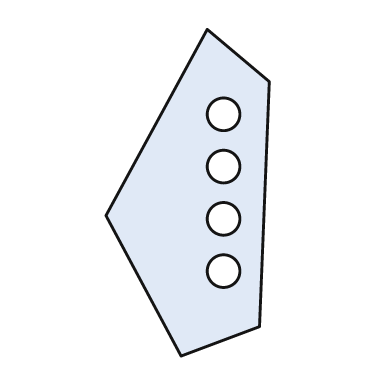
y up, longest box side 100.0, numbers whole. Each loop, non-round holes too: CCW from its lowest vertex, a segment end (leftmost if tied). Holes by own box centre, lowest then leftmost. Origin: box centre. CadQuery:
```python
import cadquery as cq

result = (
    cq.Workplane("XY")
    .moveTo(-2.0, -50.0)
    .lineTo(22.0, -41.0)
    .lineTo(25.0, 34.0)
    .lineTo(6.0, 50.0)
    .lineTo(-25.0, -7.0)
    .close()
    .moveTo(11.0, -24.0)
    .circle(5.0)
    .moveTo(11.0, -8.0)
    .circle(5.0)
    .moveTo(11.0, 8.0)
    .circle(5.0)
    .moveTo(11.0, 24.0)
    .circle(5.0)
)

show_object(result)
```